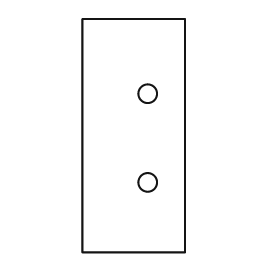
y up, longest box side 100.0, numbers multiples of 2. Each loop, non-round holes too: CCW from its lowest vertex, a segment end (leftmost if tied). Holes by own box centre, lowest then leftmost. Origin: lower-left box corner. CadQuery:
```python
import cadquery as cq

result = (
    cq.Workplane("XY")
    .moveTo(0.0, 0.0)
    .lineTo(44.0, 0.0)
    .lineTo(44.0, 100.0)
    .lineTo(0.0, 100.0)
    .close()
    .moveTo(28.0, 30.0)
    .circle(4.0)
    .moveTo(28.0, 68.0)
    .circle(4.0)
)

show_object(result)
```